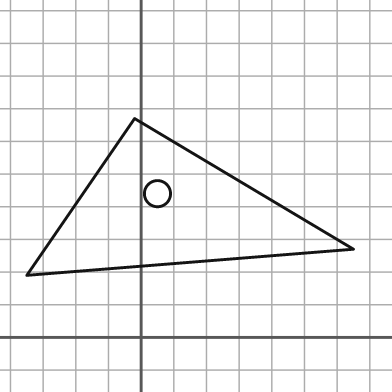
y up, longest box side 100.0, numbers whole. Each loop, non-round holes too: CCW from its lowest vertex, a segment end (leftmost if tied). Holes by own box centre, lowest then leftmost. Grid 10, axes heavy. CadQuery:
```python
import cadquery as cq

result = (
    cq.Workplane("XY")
    .moveTo(-35.0, 19.0)
    .lineTo(65.0, 27.0)
    .lineTo(-2.0, 67.0)
    .close()
    .moveTo(5.0, 44.0)
    .circle(4.0)
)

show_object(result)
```